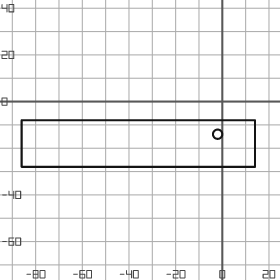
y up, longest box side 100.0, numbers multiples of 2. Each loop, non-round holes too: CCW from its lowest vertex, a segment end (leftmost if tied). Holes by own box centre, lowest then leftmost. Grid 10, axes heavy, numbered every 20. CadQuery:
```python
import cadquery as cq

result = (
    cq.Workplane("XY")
    .moveTo(-86.0, -28.0)
    .lineTo(14.0, -28.0)
    .lineTo(14.0, -8.0)
    .lineTo(-86.0, -8.0)
    .close()
    .moveTo(-2.0, -14.0)
    .circle(2.0)
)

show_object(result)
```